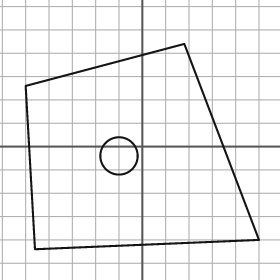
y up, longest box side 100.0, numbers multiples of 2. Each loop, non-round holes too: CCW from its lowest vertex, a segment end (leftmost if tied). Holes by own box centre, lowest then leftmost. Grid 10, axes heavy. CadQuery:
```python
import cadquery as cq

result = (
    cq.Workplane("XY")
    .moveTo(-46.0, -44.0)
    .lineTo(50.0, -40.0)
    .lineTo(18.0, 44.0)
    .lineTo(-50.0, 26.0)
    .close()
    .moveTo(-10.0, -4.0)
    .circle(8.0)
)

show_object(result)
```